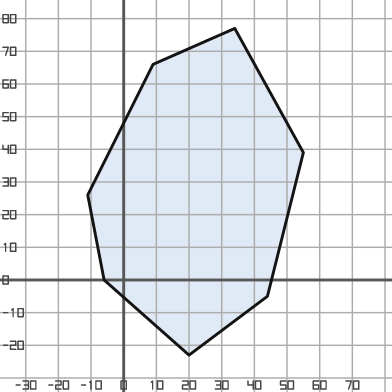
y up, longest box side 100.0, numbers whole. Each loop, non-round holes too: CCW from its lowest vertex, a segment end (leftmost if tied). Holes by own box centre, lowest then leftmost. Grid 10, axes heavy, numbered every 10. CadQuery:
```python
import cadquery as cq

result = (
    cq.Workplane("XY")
    .moveTo(20.0, -23.0)
    .lineTo(44.0, -5.0)
    .lineTo(55.0, 39.0)
    .lineTo(34.0, 77.0)
    .lineTo(9.0, 66.0)
    .lineTo(-11.0, 26.0)
    .lineTo(-6.0, 0.0)
    .close()
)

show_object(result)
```